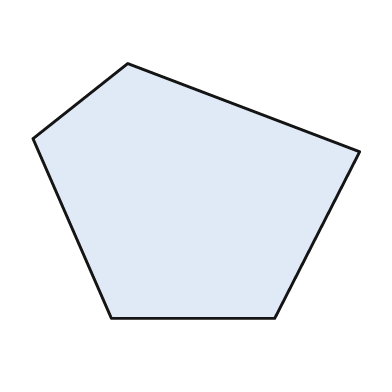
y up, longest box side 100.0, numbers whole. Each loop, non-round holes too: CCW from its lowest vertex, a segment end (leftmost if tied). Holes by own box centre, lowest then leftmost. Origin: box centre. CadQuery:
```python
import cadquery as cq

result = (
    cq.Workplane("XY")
    .moveTo(-26.0, -39.0)
    .lineTo(24.0, -39.0)
    .lineTo(50.0, 12.0)
    .lineTo(-21.0, 39.0)
    .lineTo(-50.0, 16.0)
    .close()
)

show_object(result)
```